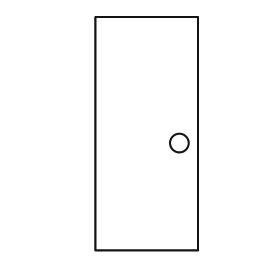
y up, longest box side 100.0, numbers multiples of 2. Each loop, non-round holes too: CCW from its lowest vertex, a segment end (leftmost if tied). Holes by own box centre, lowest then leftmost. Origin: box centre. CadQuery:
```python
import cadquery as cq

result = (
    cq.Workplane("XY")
    .moveTo(-22.0, -50.0)
    .lineTo(22.0, -50.0)
    .lineTo(22.0, 50.0)
    .lineTo(-22.0, 50.0)
    .close()
    .moveTo(14.0, -4.0)
    .circle(4.0)
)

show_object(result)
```